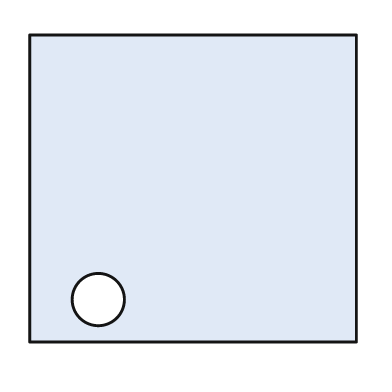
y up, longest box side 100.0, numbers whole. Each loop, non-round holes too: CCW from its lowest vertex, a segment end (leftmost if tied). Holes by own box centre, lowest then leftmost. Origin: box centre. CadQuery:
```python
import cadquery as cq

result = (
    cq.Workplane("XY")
    .moveTo(-50.0, -47.0)
    .lineTo(50.0, -47.0)
    .lineTo(50.0, 47.0)
    .lineTo(-50.0, 47.0)
    .close()
    .moveTo(-29.0, -34.0)
    .circle(8.0)
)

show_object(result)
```